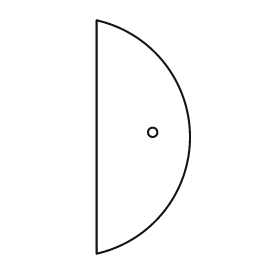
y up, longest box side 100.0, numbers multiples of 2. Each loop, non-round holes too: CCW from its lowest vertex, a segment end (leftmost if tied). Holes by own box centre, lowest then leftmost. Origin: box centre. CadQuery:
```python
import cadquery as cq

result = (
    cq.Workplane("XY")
    .moveTo(-20.0, -50.0)
    .threePointArc((20.0, 0.0), (-20.0, 50.0))
    .close()
    .moveTo(4.0, 2.0)
    .circle(2.0)
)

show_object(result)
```